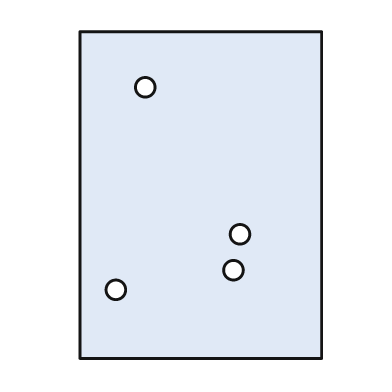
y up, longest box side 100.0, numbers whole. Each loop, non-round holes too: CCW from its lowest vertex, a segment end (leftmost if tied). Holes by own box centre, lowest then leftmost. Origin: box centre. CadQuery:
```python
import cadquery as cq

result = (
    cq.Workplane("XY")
    .moveTo(-37.0, -50.0)
    .lineTo(37.0, -50.0)
    .lineTo(37.0, 50.0)
    .lineTo(-37.0, 50.0)
    .close()
    .moveTo(-26.0, -29.0)
    .circle(3.0)
    .moveTo(10.0, -23.0)
    .circle(3.0)
    .moveTo(12.0, -12.0)
    .circle(3.0)
    .moveTo(-17.0, 33.0)
    .circle(3.0)
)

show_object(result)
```